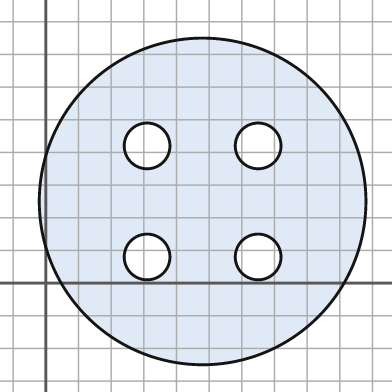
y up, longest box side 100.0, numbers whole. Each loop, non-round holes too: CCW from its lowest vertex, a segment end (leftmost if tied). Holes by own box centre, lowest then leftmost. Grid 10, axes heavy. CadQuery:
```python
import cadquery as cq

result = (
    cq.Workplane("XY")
    .moveTo(48.0, 25.0)
    .circle(50.0)
    .moveTo(31.0, 8.0)
    .circle(7.0)
    .moveTo(65.0, 8.0)
    .circle(7.0)
    .moveTo(31.0, 42.0)
    .circle(7.0)
    .moveTo(65.0, 42.0)
    .circle(7.0)
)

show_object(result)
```